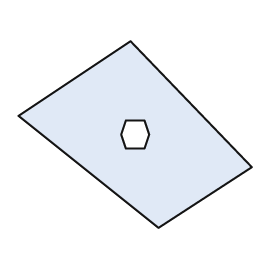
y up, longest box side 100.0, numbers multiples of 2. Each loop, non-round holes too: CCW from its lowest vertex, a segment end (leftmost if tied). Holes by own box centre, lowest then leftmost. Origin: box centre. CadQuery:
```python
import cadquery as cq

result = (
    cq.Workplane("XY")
    .moveTo(10.0, -40.0)
    .lineTo(50.0, -14.0)
    .lineTo(-2.0, 40.0)
    .lineTo(-50.0, 8.0)
    .close()
    .moveTo(-4.0, -6.0)
    .lineTo(4.0, -6.0)
    .lineTo(6.0, 0.0)
    .lineTo(4.0, 6.0)
    .lineTo(-4.0, 6.0)
    .lineTo(-6.0, 0.0)
    .close()
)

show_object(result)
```